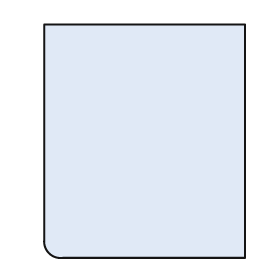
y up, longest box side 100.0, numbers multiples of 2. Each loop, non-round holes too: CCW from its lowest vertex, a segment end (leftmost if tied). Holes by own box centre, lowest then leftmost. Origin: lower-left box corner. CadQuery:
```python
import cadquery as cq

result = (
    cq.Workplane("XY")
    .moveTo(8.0, 0.0)
    .lineTo(86.0, 0.0)
    .lineTo(86.0, 100.0)
    .lineTo(0.0, 100.0)
    .lineTo(0.0, 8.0)
    .threePointArc((2.0, 2.0), (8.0, 0.0))
    .close()
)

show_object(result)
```